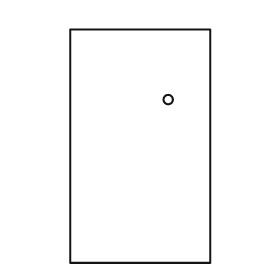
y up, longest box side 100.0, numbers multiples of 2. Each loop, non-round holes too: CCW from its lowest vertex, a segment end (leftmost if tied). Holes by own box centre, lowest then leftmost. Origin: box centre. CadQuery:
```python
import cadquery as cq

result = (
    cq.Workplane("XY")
    .moveTo(-30.0, -50.0)
    .lineTo(30.0, -50.0)
    .lineTo(30.0, 50.0)
    .lineTo(-30.0, 50.0)
    .close()
    .moveTo(12.0, 20.0)
    .circle(2.0)
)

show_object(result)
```